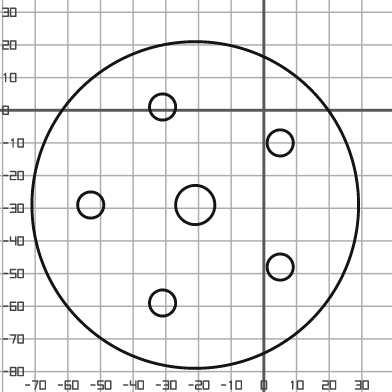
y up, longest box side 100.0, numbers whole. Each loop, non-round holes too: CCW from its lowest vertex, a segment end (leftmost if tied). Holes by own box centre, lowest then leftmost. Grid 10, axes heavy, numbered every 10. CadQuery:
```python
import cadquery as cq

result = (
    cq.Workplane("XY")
    .moveTo(-21.0, -29.0)
    .circle(50.0)
    .moveTo(-31.0, -59.0)
    .circle(4.0)
    .moveTo(5.0, -48.0)
    .circle(4.0)
    .moveTo(-53.0, -29.0)
    .circle(4.0)
    .moveTo(-21.0, -29.0)
    .circle(6.0)
    .moveTo(5.0, -10.0)
    .circle(4.0)
    .moveTo(-31.0, 1.0)
    .circle(4.0)
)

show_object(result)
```